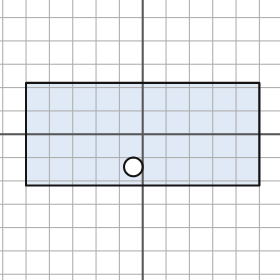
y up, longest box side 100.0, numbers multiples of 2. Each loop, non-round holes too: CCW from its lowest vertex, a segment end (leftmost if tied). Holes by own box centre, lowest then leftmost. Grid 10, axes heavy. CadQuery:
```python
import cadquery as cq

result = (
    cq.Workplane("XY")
    .moveTo(-50.0, -22.0)
    .lineTo(50.0, -22.0)
    .lineTo(50.0, 22.0)
    .lineTo(-50.0, 22.0)
    .close()
    .moveTo(-4.0, -14.0)
    .circle(4.0)
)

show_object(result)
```